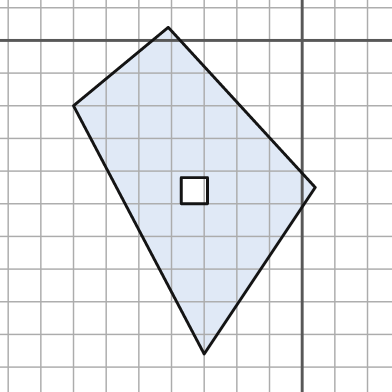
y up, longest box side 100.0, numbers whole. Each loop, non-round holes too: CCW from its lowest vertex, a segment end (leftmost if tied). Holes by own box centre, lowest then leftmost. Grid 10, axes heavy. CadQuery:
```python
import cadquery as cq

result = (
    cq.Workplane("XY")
    .moveTo(-30.0, -96.0)
    .lineTo(4.0, -45.0)
    .lineTo(-41.0, 4.0)
    .lineTo(-70.0, -20.0)
    .close()
    .moveTo(-37.0, -50.0)
    .lineTo(-29.0, -50.0)
    .lineTo(-29.0, -42.0)
    .lineTo(-37.0, -42.0)
    .close()
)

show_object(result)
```